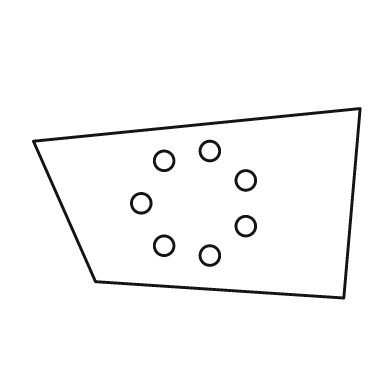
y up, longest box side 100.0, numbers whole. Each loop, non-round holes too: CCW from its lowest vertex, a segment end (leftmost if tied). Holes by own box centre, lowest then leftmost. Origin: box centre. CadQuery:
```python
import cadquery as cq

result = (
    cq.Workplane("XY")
    .moveTo(45.0, -29.0)
    .lineTo(50.0, 29.0)
    .lineTo(-50.0, 19.0)
    .lineTo(-31.0, -24.0)
    .close()
    .moveTo(4.0, -16.0)
    .circle(3.0)
    .moveTo(-10.0, -13.0)
    .circle(3.0)
    .moveTo(15.0, -7.0)
    .circle(3.0)
    .moveTo(-17.0, 0.0)
    .circle(3.0)
    .moveTo(15.0, 7.0)
    .circle(3.0)
    .moveTo(-10.0, 13.0)
    .circle(3.0)
    .moveTo(4.0, 16.0)
    .circle(3.0)
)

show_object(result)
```